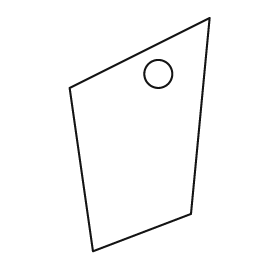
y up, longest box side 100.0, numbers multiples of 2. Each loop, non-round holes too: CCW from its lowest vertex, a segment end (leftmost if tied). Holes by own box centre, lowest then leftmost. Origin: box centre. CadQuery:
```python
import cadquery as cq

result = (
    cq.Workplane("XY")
    .moveTo(-20.0, -50.0)
    .lineTo(22.0, -34.0)
    .lineTo(30.0, 50.0)
    .lineTo(-30.0, 20.0)
    .close()
    .moveTo(8.0, 26.0)
    .circle(6.0)
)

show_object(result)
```